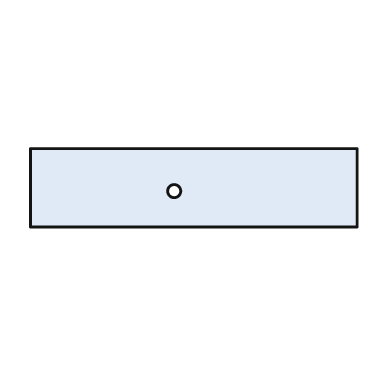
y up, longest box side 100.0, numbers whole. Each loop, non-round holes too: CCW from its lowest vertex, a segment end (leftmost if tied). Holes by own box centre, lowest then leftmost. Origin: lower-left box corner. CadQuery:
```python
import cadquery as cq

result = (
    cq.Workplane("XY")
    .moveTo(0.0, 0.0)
    .lineTo(100.0, 0.0)
    .lineTo(100.0, 24.0)
    .lineTo(0.0, 24.0)
    .close()
    .moveTo(44.0, 11.0)
    .circle(2.0)
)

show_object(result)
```